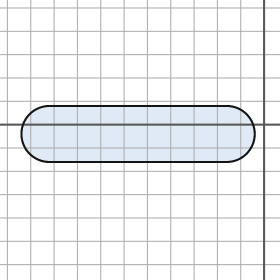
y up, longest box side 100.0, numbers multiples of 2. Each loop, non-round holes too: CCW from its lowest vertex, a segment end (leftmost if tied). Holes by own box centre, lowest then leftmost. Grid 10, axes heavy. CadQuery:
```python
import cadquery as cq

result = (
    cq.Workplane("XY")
    .moveTo(-92.0, -16.0)
    .lineTo(-16.0, -16.0)
    .threePointArc((-4.0, -4.0), (-16.0, 8.0))
    .lineTo(-92.0, 8.0)
    .threePointArc((-104.0, -4.0), (-92.0, -16.0))
    .close()
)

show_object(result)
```